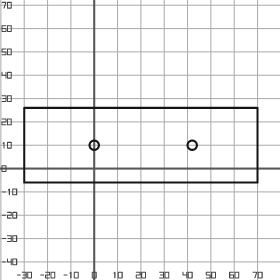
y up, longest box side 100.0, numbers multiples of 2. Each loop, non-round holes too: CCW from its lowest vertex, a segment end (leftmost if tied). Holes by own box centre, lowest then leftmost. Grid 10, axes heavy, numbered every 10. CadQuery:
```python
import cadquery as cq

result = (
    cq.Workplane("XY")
    .moveTo(-30.0, -6.0)
    .lineTo(70.0, -6.0)
    .lineTo(70.0, 26.0)
    .lineTo(-30.0, 26.0)
    .close()
    .moveTo(0.0, 10.0)
    .circle(2.0)
    .moveTo(42.0, 10.0)
    .circle(2.0)
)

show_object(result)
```